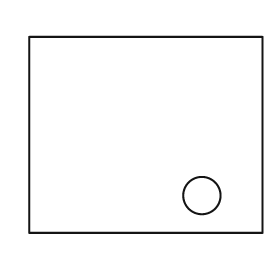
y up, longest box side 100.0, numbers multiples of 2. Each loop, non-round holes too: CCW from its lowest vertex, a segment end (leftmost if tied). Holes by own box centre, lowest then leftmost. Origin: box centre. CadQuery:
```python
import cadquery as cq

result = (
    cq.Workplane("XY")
    .moveTo(-50.0, -42.0)
    .lineTo(50.0, -42.0)
    .lineTo(50.0, 42.0)
    .lineTo(-50.0, 42.0)
    .close()
    .moveTo(24.0, -26.0)
    .circle(8.0)
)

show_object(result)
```